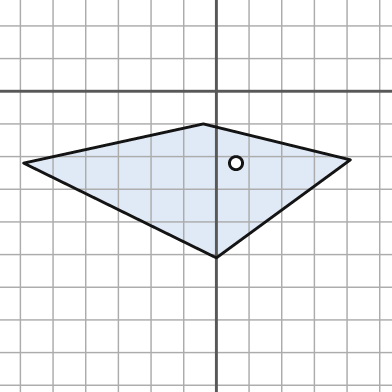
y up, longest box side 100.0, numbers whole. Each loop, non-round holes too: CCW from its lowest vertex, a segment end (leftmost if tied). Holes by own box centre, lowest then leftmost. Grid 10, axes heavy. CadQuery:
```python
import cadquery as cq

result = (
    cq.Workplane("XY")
    .moveTo(0.0, -51.0)
    .lineTo(41.0, -21.0)
    .lineTo(-4.0, -10.0)
    .lineTo(-59.0, -22.0)
    .close()
    .moveTo(6.0, -22.0)
    .circle(2.0)
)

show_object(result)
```